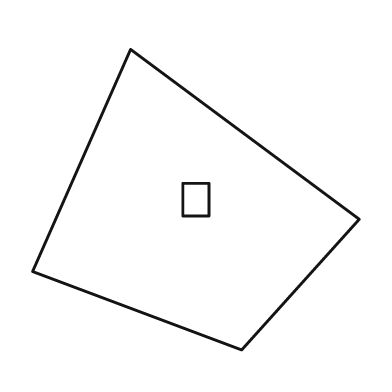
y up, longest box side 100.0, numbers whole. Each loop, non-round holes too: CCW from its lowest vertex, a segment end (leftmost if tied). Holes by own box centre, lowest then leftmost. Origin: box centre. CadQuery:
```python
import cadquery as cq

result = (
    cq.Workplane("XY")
    .moveTo(14.0, -46.0)
    .lineTo(50.0, -6.0)
    .lineTo(-20.0, 46.0)
    .lineTo(-50.0, -22.0)
    .close()
    .moveTo(-4.0, -5.0)
    .lineTo(4.0, -5.0)
    .lineTo(4.0, 5.0)
    .lineTo(-4.0, 5.0)
    .close()
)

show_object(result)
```